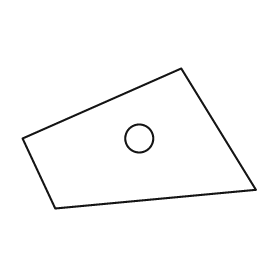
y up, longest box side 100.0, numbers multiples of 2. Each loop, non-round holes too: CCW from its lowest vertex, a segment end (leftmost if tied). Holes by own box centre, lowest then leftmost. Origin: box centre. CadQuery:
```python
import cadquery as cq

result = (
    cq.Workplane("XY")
    .moveTo(-36.0, -30.0)
    .lineTo(50.0, -22.0)
    .lineTo(18.0, 30.0)
    .lineTo(-50.0, 0.0)
    .close()
    .moveTo(0.0, 0.0)
    .circle(6.0)
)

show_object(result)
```